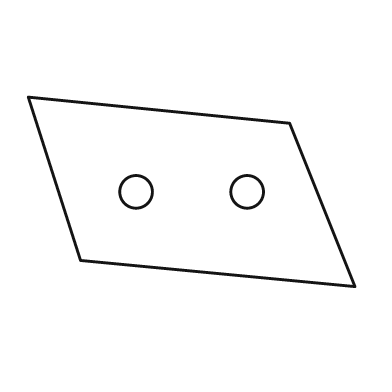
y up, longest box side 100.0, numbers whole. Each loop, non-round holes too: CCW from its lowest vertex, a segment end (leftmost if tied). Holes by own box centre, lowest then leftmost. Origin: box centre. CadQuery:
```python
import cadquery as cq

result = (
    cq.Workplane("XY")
    .moveTo(50.0, -29.0)
    .lineTo(30.0, 21.0)
    .lineTo(-50.0, 29.0)
    .lineTo(-34.0, -21.0)
    .close()
    .moveTo(-17.0, 0.0)
    .circle(5.0)
    .moveTo(17.0, 0.0)
    .circle(5.0)
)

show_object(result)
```